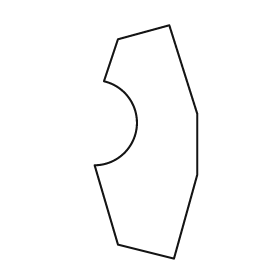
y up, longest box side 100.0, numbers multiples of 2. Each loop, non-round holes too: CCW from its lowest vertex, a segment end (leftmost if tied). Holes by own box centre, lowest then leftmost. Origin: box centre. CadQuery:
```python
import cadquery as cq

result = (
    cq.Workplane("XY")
    .moveTo(12.0, -50.0)
    .lineTo(22.0, -14.0)
    .lineTo(22.0, 12.0)
    .lineTo(10.0, 50.0)
    .lineTo(-12.0, 44.0)
    .lineTo(-18.0, 26.0)
    .threePointArc((-4.0, 6.0), (-22.0, -10.0))
    .lineTo(-12.0, -44.0)
    .close()
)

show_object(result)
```